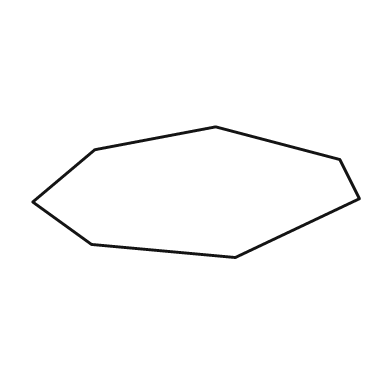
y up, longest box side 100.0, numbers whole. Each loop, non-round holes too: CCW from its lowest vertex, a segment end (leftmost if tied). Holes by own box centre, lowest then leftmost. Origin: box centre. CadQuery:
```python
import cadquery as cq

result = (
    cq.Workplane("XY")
    .moveTo(12.0, -20.0)
    .lineTo(50.0, -2.0)
    .lineTo(44.0, 10.0)
    .lineTo(6.0, 20.0)
    .lineTo(-31.0, 13.0)
    .lineTo(-50.0, -3.0)
    .lineTo(-32.0, -16.0)
    .close()
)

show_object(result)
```